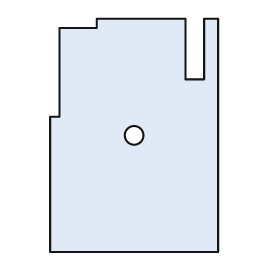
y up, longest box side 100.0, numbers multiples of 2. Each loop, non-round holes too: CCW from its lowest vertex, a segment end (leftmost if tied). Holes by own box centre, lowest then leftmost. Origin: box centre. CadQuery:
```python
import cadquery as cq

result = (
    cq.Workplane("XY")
    .moveTo(-36.0, -50.0)
    .lineTo(36.0, -50.0)
    .lineTo(36.0, 50.0)
    .lineTo(30.0, 50.0)
    .lineTo(30.0, 24.0)
    .lineTo(22.0, 24.0)
    .lineTo(22.0, 50.0)
    .lineTo(-16.0, 50.0)
    .lineTo(-16.0, 46.0)
    .lineTo(-32.0, 46.0)
    .lineTo(-32.0, 8.0)
    .lineTo(-36.0, 8.0)
    .close()
    .moveTo(0.0, 0.0)
    .circle(4.0)
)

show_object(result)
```